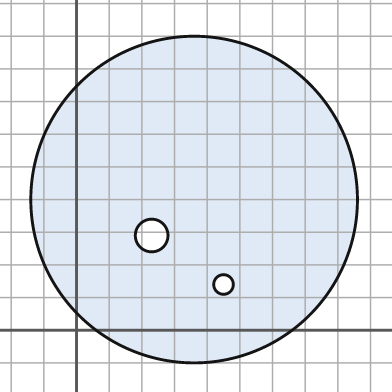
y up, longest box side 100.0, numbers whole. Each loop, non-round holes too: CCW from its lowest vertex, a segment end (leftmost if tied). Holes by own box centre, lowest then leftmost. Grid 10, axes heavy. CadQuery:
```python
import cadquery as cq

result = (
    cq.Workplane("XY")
    .moveTo(36.0, 40.0)
    .circle(50.0)
    .moveTo(45.0, 14.0)
    .circle(3.0)
    .moveTo(23.0, 29.0)
    .circle(5.0)
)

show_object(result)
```